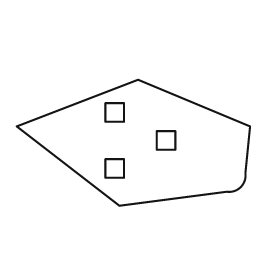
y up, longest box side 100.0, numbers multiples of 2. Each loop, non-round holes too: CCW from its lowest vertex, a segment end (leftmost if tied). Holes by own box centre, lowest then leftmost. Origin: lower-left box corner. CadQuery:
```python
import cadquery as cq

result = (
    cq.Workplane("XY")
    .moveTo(44.0, 0.0)
    .lineTo(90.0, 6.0)
    .threePointArc((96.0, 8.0), (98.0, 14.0))
    .lineTo(100.0, 34.0)
    .lineTo(52.0, 54.0)
    .lineTo(0.0, 34.0)
    .close()
    .moveTo(38.0, 12.0)
    .lineTo(46.0, 12.0)
    .lineTo(46.0, 20.0)
    .lineTo(38.0, 20.0)
    .close()
    .moveTo(60.0, 24.0)
    .lineTo(68.0, 24.0)
    .lineTo(68.0, 32.0)
    .lineTo(60.0, 32.0)
    .close()
    .moveTo(38.0, 36.0)
    .lineTo(46.0, 36.0)
    .lineTo(46.0, 44.0)
    .lineTo(38.0, 44.0)
    .close()
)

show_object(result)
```